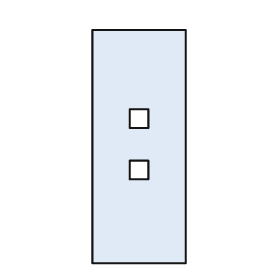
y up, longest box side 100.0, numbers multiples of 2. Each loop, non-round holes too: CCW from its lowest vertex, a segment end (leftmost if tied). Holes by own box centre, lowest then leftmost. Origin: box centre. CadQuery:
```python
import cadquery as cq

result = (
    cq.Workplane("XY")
    .moveTo(-20.0, -50.0)
    .lineTo(20.0, -50.0)
    .lineTo(20.0, 50.0)
    .lineTo(-20.0, 50.0)
    .close()
    .moveTo(-4.0, -14.0)
    .lineTo(4.0, -14.0)
    .lineTo(4.0, -6.0)
    .lineTo(-4.0, -6.0)
    .close()
    .moveTo(-4.0, 8.0)
    .lineTo(4.0, 8.0)
    .lineTo(4.0, 16.0)
    .lineTo(-4.0, 16.0)
    .close()
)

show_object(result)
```